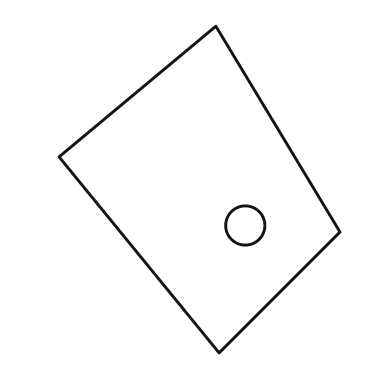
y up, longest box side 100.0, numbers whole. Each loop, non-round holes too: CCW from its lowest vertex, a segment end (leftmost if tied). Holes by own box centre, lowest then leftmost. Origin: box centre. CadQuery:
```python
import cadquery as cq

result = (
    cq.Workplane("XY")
    .moveTo(6.0, -50.0)
    .lineTo(43.0, -13.0)
    .lineTo(5.0, 50.0)
    .lineTo(-43.0, 10.0)
    .close()
    .moveTo(14.0, -11.0)
    .circle(6.0)
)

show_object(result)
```